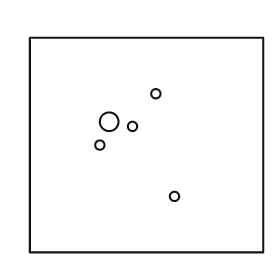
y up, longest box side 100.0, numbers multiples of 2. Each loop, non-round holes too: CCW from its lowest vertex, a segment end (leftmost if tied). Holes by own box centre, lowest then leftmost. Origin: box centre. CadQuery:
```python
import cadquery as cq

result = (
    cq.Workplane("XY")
    .moveTo(-50.0, -46.0)
    .lineTo(50.0, -46.0)
    .lineTo(50.0, 46.0)
    .lineTo(-50.0, 46.0)
    .close()
    .moveTo(12.0, -22.0)
    .circle(2.0)
    .moveTo(-20.0, 0.0)
    .circle(2.0)
    .moveTo(-6.0, 8.0)
    .circle(2.0)
    .moveTo(-16.0, 10.0)
    .circle(4.0)
    .moveTo(4.0, 22.0)
    .circle(2.0)
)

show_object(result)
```